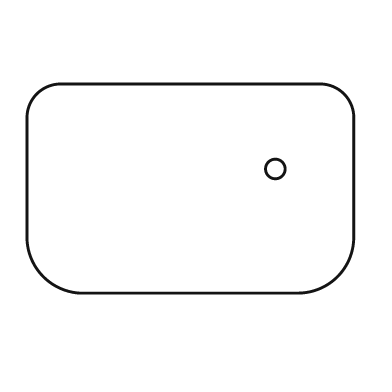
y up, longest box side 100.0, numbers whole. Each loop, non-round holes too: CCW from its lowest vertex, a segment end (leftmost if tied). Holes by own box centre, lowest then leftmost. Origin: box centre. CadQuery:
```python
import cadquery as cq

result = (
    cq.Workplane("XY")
    .moveTo(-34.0, -32.0)
    .lineTo(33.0, -32.0)
    .threePointArc((45.0, -27.0), (50.0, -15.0))
    .lineTo(50.0, 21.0)
    .threePointArc((47.0, 29.0), (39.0, 32.0))
    .lineTo(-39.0, 32.0)
    .threePointArc((-47.0, 29.0), (-50.0, 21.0))
    .lineTo(-50.0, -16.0)
    .threePointArc((-45.0, -27.0), (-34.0, -32.0))
    .close()
    .moveTo(26.0, 6.0)
    .circle(3.0)
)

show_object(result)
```